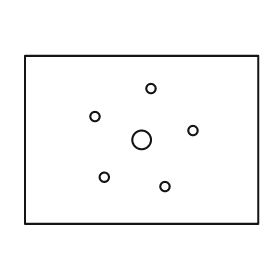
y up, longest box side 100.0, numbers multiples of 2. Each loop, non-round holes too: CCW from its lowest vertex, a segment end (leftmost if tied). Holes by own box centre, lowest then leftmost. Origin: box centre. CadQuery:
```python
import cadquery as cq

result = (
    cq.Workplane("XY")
    .moveTo(-50.0, -36.0)
    .lineTo(50.0, -36.0)
    .lineTo(50.0, 36.0)
    .lineTo(-50.0, 36.0)
    .close()
    .moveTo(10.0, -20.0)
    .circle(2.0)
    .moveTo(-16.0, -16.0)
    .circle(2.0)
    .moveTo(0.0, 0.0)
    .circle(4.0)
    .moveTo(22.0, 4.0)
    .circle(2.0)
    .moveTo(-20.0, 10.0)
    .circle(2.0)
    .moveTo(4.0, 22.0)
    .circle(2.0)
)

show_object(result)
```